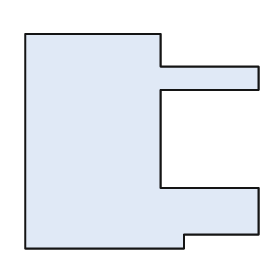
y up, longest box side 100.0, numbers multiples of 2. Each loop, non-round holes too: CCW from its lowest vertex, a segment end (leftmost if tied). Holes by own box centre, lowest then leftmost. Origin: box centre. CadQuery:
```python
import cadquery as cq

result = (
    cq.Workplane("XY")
    .moveTo(-50.0, -46.0)
    .lineTo(18.0, -46.0)
    .lineTo(18.0, -40.0)
    .lineTo(50.0, -40.0)
    .lineTo(50.0, -20.0)
    .lineTo(8.0, -20.0)
    .lineTo(8.0, 22.0)
    .lineTo(50.0, 22.0)
    .lineTo(50.0, 32.0)
    .lineTo(8.0, 32.0)
    .lineTo(8.0, 46.0)
    .lineTo(-50.0, 46.0)
    .close()
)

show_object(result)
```